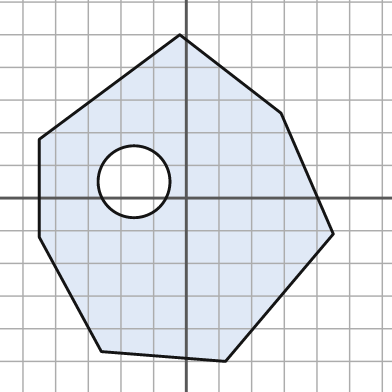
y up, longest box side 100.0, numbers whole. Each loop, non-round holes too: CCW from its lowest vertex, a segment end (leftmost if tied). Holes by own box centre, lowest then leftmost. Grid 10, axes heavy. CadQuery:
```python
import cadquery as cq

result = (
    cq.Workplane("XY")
    .moveTo(12.0, -50.0)
    .lineTo(45.0, -11.0)
    .lineTo(29.0, 26.0)
    .lineTo(-2.0, 50.0)
    .lineTo(-45.0, 18.0)
    .lineTo(-45.0, -12.0)
    .lineTo(-26.0, -47.0)
    .close()
    .moveTo(-16.0, 5.0)
    .circle(11.0)
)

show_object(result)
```